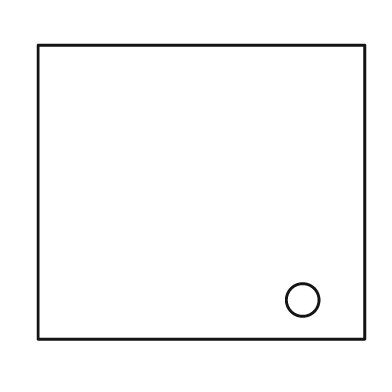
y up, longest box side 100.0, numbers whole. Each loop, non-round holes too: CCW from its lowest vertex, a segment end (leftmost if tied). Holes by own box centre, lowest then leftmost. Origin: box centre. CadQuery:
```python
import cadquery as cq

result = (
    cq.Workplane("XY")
    .moveTo(-50.0, -45.0)
    .lineTo(50.0, -45.0)
    .lineTo(50.0, 45.0)
    .lineTo(-50.0, 45.0)
    .close()
    .moveTo(31.0, -33.0)
    .circle(5.0)
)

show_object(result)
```